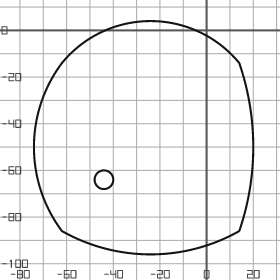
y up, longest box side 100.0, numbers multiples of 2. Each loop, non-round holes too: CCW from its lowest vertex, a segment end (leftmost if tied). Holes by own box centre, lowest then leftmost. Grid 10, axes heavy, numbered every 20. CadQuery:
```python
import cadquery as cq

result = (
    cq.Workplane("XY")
    .moveTo(-62.0, -86.0)
    .threePointArc((-24.0, -96.0), (14.0, -86.0))
    .threePointArc((20.0, -50.0), (14.0, -14.0))
    .threePointArc((-24.0, 4.0), (-62.0, -14.0))
    .threePointArc((-74.0, -50.0), (-62.0, -86.0))
    .close()
    .moveTo(-44.0, -64.0)
    .circle(4.0)
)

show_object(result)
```